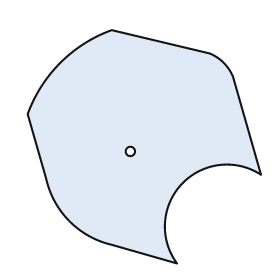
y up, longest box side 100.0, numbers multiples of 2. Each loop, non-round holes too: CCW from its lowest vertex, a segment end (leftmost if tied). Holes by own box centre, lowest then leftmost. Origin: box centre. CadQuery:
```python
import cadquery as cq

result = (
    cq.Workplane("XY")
    .moveTo(14.0, -50.0)
    .threePointArc((16.0, -16.0), (50.0, -12.0))
    .lineTo(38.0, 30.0)
    .threePointArc((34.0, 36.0), (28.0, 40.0))
    .lineTo(-14.0, 50.0)
    .threePointArc((-36.0, 36.0), (-50.0, 14.0))
    .lineTo(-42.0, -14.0)
    .threePointArc((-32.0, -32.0), (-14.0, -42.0))
    .close()
    .moveTo(-6.0, -2.0)
    .circle(2.0)
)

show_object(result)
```